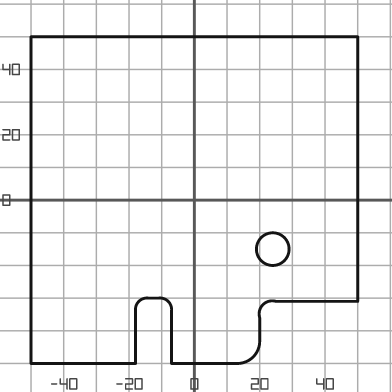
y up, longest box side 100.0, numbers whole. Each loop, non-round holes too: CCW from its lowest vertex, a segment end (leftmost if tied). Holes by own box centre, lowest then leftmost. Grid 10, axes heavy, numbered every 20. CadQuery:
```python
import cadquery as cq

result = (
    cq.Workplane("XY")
    .moveTo(-50.0, -50.0)
    .lineTo(-18.0, -50.0)
    .lineTo(-18.0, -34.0)
    .threePointArc((-17.0, -31.0), (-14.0, -30.0))
    .lineTo(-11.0, -30.0)
    .threePointArc((-8.0, -31.0), (-7.0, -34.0))
    .lineTo(-7.0, -50.0)
    .lineTo(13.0, -50.0)
    .threePointArc((18.0, -48.0), (20.0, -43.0))
    .lineTo(20.0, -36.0)
    .threePointArc((21.0, -32.0), (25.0, -31.0))
    .lineTo(50.0, -31.0)
    .lineTo(50.0, 50.0)
    .lineTo(-50.0, 50.0)
    .close()
    .moveTo(24.0, -15.0)
    .circle(5.0)
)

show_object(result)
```